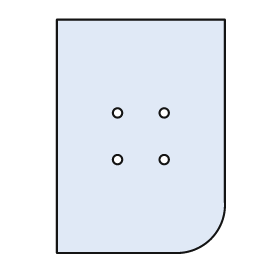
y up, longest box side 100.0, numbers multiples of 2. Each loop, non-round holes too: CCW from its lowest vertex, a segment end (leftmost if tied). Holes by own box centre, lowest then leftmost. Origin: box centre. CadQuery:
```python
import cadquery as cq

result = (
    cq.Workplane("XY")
    .moveTo(-36.0, -50.0)
    .lineTo(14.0, -50.0)
    .threePointArc((30.0, -44.0), (36.0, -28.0))
    .lineTo(36.0, 50.0)
    .lineTo(-36.0, 50.0)
    .close()
    .moveTo(-10.0, -10.0)
    .circle(2.0)
    .moveTo(10.0, -10.0)
    .circle(2.0)
    .moveTo(-10.0, 10.0)
    .circle(2.0)
    .moveTo(10.0, 10.0)
    .circle(2.0)
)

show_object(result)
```